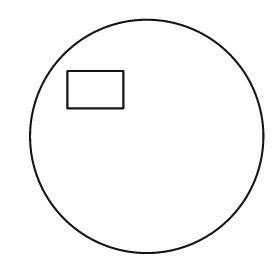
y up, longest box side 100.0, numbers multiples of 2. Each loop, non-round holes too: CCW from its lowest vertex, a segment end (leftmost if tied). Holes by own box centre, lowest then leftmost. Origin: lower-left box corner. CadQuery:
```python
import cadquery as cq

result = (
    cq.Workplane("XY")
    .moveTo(50.0, 50.0)
    .circle(50.0)
    .moveTo(16.0, 62.0)
    .lineTo(40.0, 62.0)
    .lineTo(40.0, 78.0)
    .lineTo(16.0, 78.0)
    .close()
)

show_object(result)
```